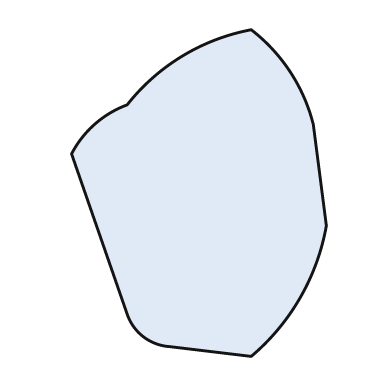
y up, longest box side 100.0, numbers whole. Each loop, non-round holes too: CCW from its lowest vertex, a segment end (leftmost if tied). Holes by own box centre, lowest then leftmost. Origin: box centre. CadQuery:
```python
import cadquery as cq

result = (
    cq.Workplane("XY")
    .moveTo(16.0, -50.0)
    .threePointArc((31.0, -32.0), (39.0, -10.0))
    .lineTo(35.0, 21.0)
    .threePointArc((28.0, 37.0), (16.0, 50.0))
    .threePointArc((-5.0, 42.0), (-22.0, 27.0))
    .threePointArc((-32.0, 21.0), (-39.0, 12.0))
    .lineTo(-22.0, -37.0)
    .threePointArc((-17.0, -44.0), (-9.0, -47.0))
    .close()
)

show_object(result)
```